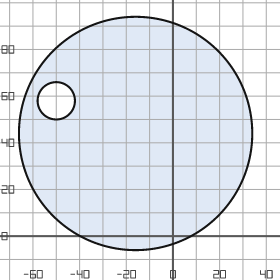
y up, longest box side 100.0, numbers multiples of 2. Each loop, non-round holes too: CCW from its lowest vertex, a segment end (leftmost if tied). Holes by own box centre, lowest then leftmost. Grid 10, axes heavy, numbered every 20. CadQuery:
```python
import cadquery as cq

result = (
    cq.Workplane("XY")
    .moveTo(-16.0, 44.0)
    .circle(50.0)
    .moveTo(-50.0, 58.0)
    .circle(8.0)
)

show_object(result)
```